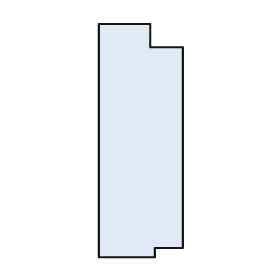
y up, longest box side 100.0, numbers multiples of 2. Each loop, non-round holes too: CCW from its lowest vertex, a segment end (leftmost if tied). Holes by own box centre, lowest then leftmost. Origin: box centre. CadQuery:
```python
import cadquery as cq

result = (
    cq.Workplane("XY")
    .moveTo(-18.0, -50.0)
    .lineTo(6.0, -50.0)
    .lineTo(6.0, -46.0)
    .lineTo(18.0, -46.0)
    .lineTo(18.0, 40.0)
    .lineTo(4.0, 40.0)
    .lineTo(4.0, 50.0)
    .lineTo(-18.0, 50.0)
    .close()
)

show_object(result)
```